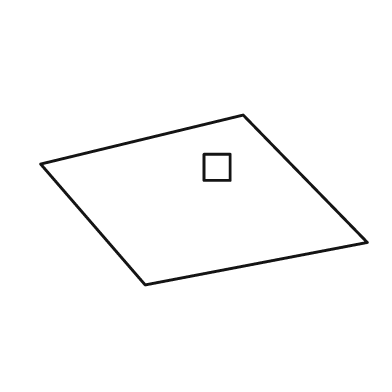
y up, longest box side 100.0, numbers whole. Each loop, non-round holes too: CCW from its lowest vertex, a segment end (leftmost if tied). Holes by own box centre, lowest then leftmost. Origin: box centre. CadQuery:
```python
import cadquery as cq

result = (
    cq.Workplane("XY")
    .moveTo(-18.0, -26.0)
    .lineTo(50.0, -13.0)
    .lineTo(12.0, 26.0)
    .lineTo(-50.0, 11.0)
    .close()
    .moveTo(0.0, 6.0)
    .lineTo(8.0, 6.0)
    .lineTo(8.0, 14.0)
    .lineTo(0.0, 14.0)
    .close()
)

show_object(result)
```